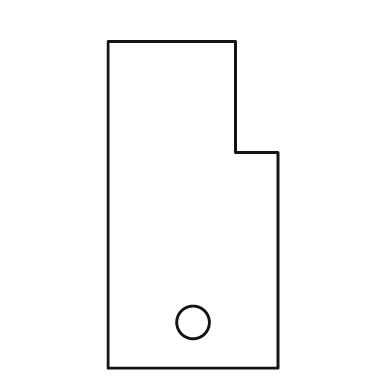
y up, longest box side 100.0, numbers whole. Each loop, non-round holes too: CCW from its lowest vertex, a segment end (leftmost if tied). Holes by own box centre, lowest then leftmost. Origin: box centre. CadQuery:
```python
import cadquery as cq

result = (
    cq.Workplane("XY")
    .moveTo(-26.0, -50.0)
    .lineTo(26.0, -50.0)
    .lineTo(26.0, 16.0)
    .lineTo(13.0, 16.0)
    .lineTo(13.0, 50.0)
    .lineTo(-26.0, 50.0)
    .close()
    .moveTo(0.0, -36.0)
    .circle(5.0)
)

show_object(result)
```